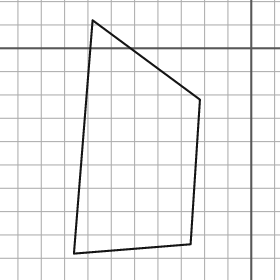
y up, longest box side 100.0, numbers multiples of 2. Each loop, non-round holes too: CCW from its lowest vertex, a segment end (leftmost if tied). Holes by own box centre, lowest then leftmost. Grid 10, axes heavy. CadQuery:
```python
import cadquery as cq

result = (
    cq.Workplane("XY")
    .moveTo(-76.0, -88.0)
    .lineTo(-26.0, -84.0)
    .lineTo(-22.0, -22.0)
    .lineTo(-68.0, 12.0)
    .close()
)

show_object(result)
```